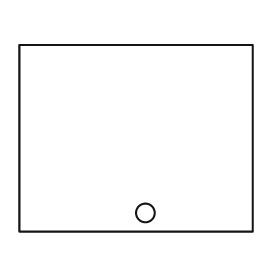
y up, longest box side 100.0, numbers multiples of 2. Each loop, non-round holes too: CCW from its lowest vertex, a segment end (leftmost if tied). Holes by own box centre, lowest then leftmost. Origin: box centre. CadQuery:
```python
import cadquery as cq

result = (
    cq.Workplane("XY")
    .moveTo(-50.0, -40.0)
    .lineTo(50.0, -40.0)
    .lineTo(50.0, 40.0)
    .lineTo(-50.0, 40.0)
    .close()
    .moveTo(4.0, -32.0)
    .circle(4.0)
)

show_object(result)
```